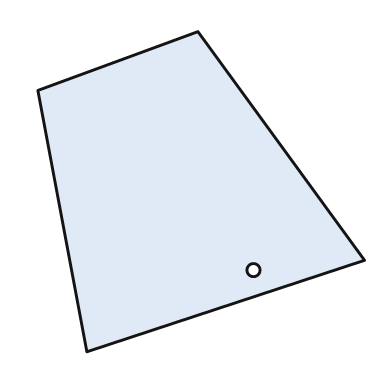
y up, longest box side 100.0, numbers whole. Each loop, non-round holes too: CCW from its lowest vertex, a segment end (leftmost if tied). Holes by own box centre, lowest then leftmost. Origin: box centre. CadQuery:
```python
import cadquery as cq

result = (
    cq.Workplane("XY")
    .moveTo(-35.0, -49.0)
    .lineTo(50.0, -21.0)
    .lineTo(-1.0, 49.0)
    .lineTo(-50.0, 31.0)
    .close()
    .moveTo(16.0, -24.0)
    .circle(2.0)
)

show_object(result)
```